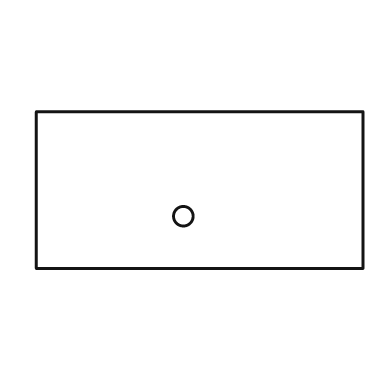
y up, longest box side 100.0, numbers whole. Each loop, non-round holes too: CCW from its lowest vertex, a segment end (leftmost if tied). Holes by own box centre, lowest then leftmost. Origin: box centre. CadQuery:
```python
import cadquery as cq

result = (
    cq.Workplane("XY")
    .moveTo(-50.0, -24.0)
    .lineTo(50.0, -24.0)
    .lineTo(50.0, 24.0)
    .lineTo(-50.0, 24.0)
    .close()
    .moveTo(-5.0, -8.0)
    .circle(3.0)
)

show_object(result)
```